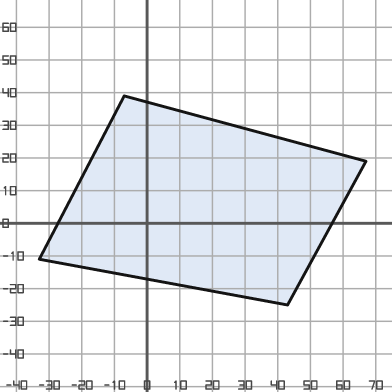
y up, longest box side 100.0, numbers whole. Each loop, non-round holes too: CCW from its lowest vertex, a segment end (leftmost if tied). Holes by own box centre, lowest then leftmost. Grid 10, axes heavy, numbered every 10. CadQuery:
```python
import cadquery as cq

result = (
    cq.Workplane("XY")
    .moveTo(43.0, -25.0)
    .lineTo(67.0, 19.0)
    .lineTo(-7.0, 39.0)
    .lineTo(-33.0, -11.0)
    .close()
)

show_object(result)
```